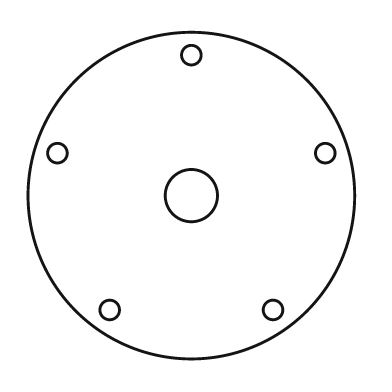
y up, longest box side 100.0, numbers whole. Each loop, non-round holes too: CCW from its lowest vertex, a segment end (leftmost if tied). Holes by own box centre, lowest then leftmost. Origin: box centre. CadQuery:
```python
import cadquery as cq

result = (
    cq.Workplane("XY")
    .moveTo(0.0, 0.0)
    .circle(50.0)
    .moveTo(-25.0, -35.0)
    .circle(3.0)
    .moveTo(25.0, -35.0)
    .circle(3.0)
    .moveTo(0.0, 0.0)
    .circle(8.0)
    .moveTo(-41.0, 13.0)
    .circle(3.0)
    .moveTo(41.0, 13.0)
    .circle(3.0)
    .moveTo(0.0, 43.0)
    .circle(3.0)
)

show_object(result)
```